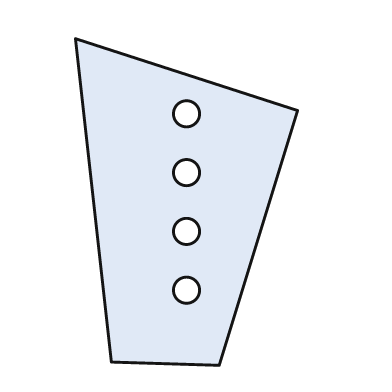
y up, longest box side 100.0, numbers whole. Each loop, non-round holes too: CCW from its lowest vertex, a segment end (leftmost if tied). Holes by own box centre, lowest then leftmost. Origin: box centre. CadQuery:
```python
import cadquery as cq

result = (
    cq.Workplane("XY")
    .moveTo(10.0, -50.0)
    .lineTo(34.0, 28.0)
    .lineTo(-34.0, 50.0)
    .lineTo(-23.0, -49.0)
    .close()
    .moveTo(0.0, -27.0)
    .circle(4.0)
    .moveTo(0.0, -9.0)
    .circle(4.0)
    .moveTo(0.0, 9.0)
    .circle(4.0)
    .moveTo(0.0, 27.0)
    .circle(4.0)
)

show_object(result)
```